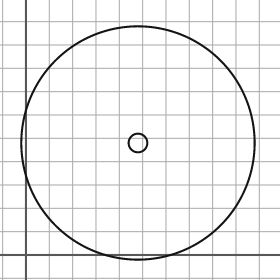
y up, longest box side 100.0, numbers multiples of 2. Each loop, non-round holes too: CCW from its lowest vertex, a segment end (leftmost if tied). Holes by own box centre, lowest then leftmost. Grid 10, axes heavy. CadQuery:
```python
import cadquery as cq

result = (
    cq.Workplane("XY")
    .moveTo(48.0, 48.0)
    .circle(50.0)
    .moveTo(48.0, 48.0)
    .circle(4.0)
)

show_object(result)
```